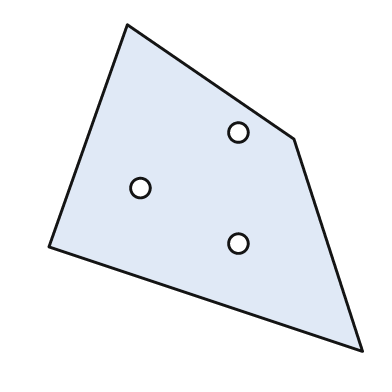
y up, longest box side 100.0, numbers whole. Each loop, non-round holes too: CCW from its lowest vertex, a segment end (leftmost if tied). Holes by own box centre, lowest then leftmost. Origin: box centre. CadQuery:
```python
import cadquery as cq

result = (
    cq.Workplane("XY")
    .moveTo(48.0, -50.0)
    .lineTo(27.0, 15.0)
    .lineTo(-24.0, 50.0)
    .lineTo(-48.0, -18.0)
    .close()
    .moveTo(10.0, -17.0)
    .circle(3.0)
    .moveTo(-20.0, 0.0)
    .circle(3.0)
    .moveTo(10.0, 17.0)
    .circle(3.0)
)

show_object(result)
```